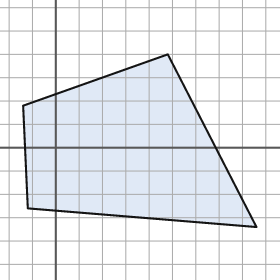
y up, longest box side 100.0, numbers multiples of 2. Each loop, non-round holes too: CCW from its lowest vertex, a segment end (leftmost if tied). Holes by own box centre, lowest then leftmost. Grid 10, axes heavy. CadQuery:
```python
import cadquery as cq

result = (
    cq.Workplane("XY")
    .moveTo(86.0, -34.0)
    .lineTo(48.0, 40.0)
    .lineTo(-14.0, 18.0)
    .lineTo(-12.0, -26.0)
    .close()
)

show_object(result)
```